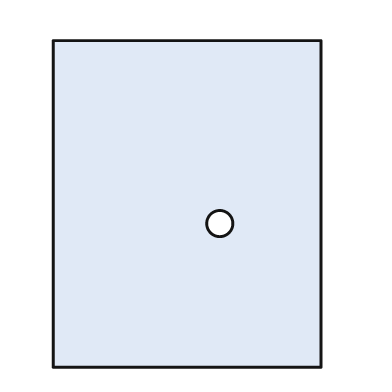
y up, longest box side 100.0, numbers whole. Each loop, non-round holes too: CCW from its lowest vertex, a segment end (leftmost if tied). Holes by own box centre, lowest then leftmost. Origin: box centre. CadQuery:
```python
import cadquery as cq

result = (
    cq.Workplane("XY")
    .moveTo(-41.0, -50.0)
    .lineTo(41.0, -50.0)
    .lineTo(41.0, 50.0)
    .lineTo(-41.0, 50.0)
    .close()
    .moveTo(10.0, -6.0)
    .circle(4.0)
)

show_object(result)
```